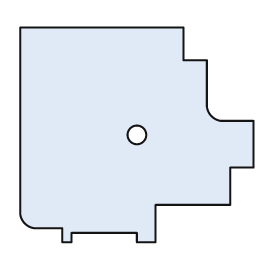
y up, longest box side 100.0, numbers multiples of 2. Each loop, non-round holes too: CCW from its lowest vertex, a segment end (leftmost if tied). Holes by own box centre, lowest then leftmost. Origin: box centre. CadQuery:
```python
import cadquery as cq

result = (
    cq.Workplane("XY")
    .moveTo(-32.0, -46.0)
    .lineTo(-28.0, -46.0)
    .lineTo(-28.0, -42.0)
    .lineTo(0.0, -42.0)
    .lineTo(0.0, -46.0)
    .lineTo(8.0, -46.0)
    .lineTo(8.0, -30.0)
    .lineTo(40.0, -30.0)
    .lineTo(40.0, -14.0)
    .lineTo(50.0, -14.0)
    .lineTo(50.0, 6.0)
    .lineTo(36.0, 6.0)
    .threePointArc((32.0, 8.0), (30.0, 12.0))
    .lineTo(30.0, 32.0)
    .lineTo(20.0, 32.0)
    .lineTo(20.0, 46.0)
    .lineTo(-50.0, 46.0)
    .lineTo(-50.0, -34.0)
    .threePointArc((-48.0, -38.0), (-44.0, -40.0))
    .lineTo(-32.0, -40.0)
    .close()
    .moveTo(0.0, 0.0)
    .circle(4.0)
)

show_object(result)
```